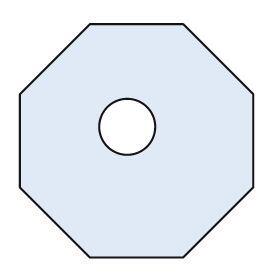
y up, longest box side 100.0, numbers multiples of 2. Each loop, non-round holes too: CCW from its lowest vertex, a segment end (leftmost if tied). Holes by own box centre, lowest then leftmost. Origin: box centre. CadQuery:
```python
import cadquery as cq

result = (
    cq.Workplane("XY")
    .moveTo(-20.0, -50.0)
    .lineTo(20.0, -50.0)
    .lineTo(50.0, -20.0)
    .lineTo(50.0, 20.0)
    .lineTo(20.0, 50.0)
    .lineTo(-20.0, 50.0)
    .lineTo(-50.0, 20.0)
    .lineTo(-50.0, -20.0)
    .close()
    .moveTo(-4.0, 6.0)
    .circle(12.0)
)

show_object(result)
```